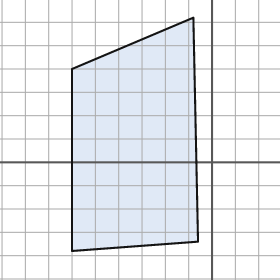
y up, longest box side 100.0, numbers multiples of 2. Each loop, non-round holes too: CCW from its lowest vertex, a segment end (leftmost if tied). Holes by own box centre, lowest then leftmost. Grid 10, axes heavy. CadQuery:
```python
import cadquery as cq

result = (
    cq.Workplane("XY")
    .moveTo(-60.0, -38.0)
    .lineTo(-6.0, -34.0)
    .lineTo(-8.0, 62.0)
    .lineTo(-60.0, 40.0)
    .close()
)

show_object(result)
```